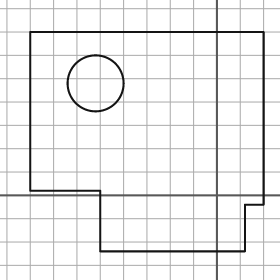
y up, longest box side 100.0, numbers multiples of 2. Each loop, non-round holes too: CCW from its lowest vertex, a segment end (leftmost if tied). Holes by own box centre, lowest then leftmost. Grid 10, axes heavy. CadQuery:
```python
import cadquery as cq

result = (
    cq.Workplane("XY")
    .moveTo(-50.0, -24.0)
    .lineTo(12.0, -24.0)
    .lineTo(12.0, -4.0)
    .lineTo(20.0, -4.0)
    .lineTo(20.0, 70.0)
    .lineTo(-80.0, 70.0)
    .lineTo(-80.0, 2.0)
    .lineTo(-50.0, 2.0)
    .close()
    .moveTo(-52.0, 48.0)
    .circle(12.0)
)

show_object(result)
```